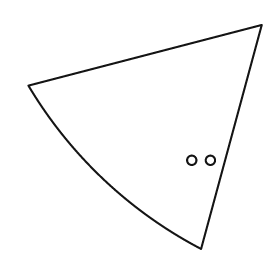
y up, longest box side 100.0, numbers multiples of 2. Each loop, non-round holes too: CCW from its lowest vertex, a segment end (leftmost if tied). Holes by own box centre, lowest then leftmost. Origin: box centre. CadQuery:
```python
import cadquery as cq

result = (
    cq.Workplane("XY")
    .moveTo(24.0, -48.0)
    .lineTo(50.0, 48.0)
    .lineTo(-50.0, 22.0)
    .threePointArc((-18.0, -18.0), (24.0, -48.0))
    .close()
    .moveTo(20.0, -10.0)
    .circle(2.0)
    .moveTo(28.0, -10.0)
    .circle(2.0)
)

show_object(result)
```